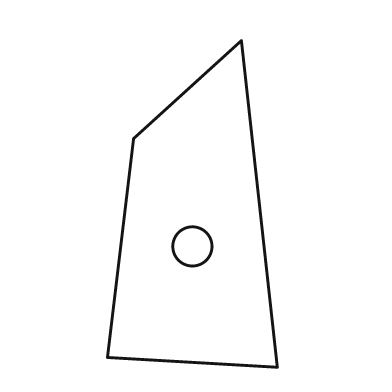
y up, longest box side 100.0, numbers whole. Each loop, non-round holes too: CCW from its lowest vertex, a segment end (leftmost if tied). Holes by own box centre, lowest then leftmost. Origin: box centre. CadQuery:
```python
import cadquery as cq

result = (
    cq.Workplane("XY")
    .moveTo(26.0, -50.0)
    .lineTo(15.0, 50.0)
    .lineTo(-18.0, 20.0)
    .lineTo(-26.0, -47.0)
    .close()
    .moveTo(0.0, -13.0)
    .circle(6.0)
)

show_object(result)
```